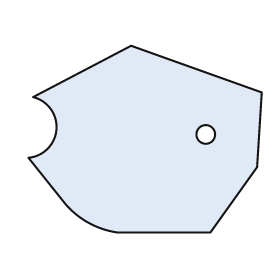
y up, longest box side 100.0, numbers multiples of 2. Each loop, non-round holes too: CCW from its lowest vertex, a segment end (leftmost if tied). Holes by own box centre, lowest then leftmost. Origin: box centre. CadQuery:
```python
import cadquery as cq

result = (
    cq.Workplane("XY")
    .moveTo(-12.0, -40.0)
    .lineTo(28.0, -40.0)
    .lineTo(48.0, -12.0)
    .lineTo(50.0, 20.0)
    .lineTo(-6.0, 40.0)
    .lineTo(-48.0, 18.0)
    .threePointArc((-38.0, 4.0), (-50.0, -8.0))
    .lineTo(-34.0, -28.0)
    .threePointArc((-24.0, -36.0), (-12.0, -40.0))
    .close()
    .moveTo(26.0, 2.0)
    .circle(4.0)
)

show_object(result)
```